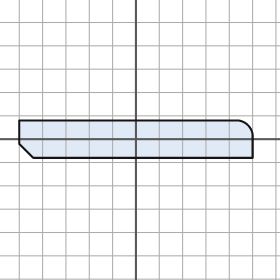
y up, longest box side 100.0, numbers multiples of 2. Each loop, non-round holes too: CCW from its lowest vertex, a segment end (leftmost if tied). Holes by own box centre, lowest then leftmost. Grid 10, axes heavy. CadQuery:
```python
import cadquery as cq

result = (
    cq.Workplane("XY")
    .moveTo(-44.0, -8.0)
    .lineTo(50.0, -8.0)
    .lineTo(50.0, 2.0)
    .threePointArc((48.0, 6.0), (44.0, 8.0))
    .lineTo(-50.0, 8.0)
    .lineTo(-50.0, -2.0)
    .close()
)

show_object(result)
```